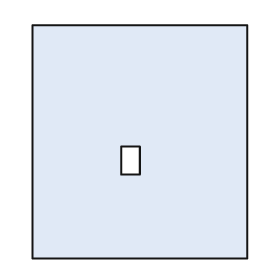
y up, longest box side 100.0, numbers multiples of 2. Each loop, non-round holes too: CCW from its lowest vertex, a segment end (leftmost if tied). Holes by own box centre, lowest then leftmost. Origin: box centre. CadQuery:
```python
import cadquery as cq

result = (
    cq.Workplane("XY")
    .moveTo(-46.0, -50.0)
    .lineTo(46.0, -50.0)
    .lineTo(46.0, 50.0)
    .lineTo(-46.0, 50.0)
    .close()
    .moveTo(-8.0, -14.0)
    .lineTo(0.0, -14.0)
    .lineTo(0.0, -2.0)
    .lineTo(-8.0, -2.0)
    .close()
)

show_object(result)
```